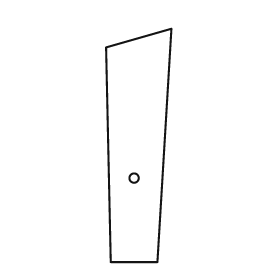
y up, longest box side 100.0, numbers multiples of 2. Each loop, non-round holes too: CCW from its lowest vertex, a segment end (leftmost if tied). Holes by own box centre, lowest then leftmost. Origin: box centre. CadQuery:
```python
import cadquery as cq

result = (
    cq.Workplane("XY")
    .moveTo(-12.0, -50.0)
    .lineTo(8.0, -50.0)
    .lineTo(14.0, 50.0)
    .lineTo(-14.0, 42.0)
    .close()
    .moveTo(-2.0, -14.0)
    .circle(2.0)
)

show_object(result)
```